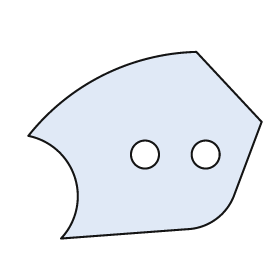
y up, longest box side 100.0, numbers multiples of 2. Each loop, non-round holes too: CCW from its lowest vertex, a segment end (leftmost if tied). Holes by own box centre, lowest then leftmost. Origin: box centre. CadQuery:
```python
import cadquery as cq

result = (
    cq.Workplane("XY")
    .moveTo(-36.0, -40.0)
    .lineTo(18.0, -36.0)
    .threePointArc((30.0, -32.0), (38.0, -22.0))
    .lineTo(50.0, 10.0)
    .lineTo(22.0, 40.0)
    .threePointArc((-18.0, 30.0), (-50.0, 4.0))
    .threePointArc((-30.0, -14.0), (-36.0, -40.0))
    .close()
    .moveTo(0.0, -4.0)
    .circle(6.0)
    .moveTo(26.0, -4.0)
    .circle(6.0)
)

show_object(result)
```